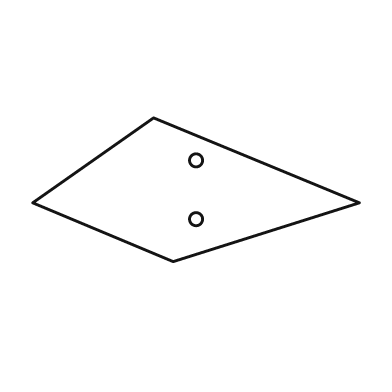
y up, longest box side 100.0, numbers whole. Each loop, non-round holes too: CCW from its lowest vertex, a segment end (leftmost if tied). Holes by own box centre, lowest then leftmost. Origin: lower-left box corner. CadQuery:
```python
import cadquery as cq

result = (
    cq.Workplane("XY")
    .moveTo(43.0, 0.0)
    .lineTo(100.0, 18.0)
    .lineTo(37.0, 44.0)
    .lineTo(0.0, 18.0)
    .close()
    .moveTo(50.0, 13.0)
    .circle(2.0)
    .moveTo(50.0, 31.0)
    .circle(2.0)
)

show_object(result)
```